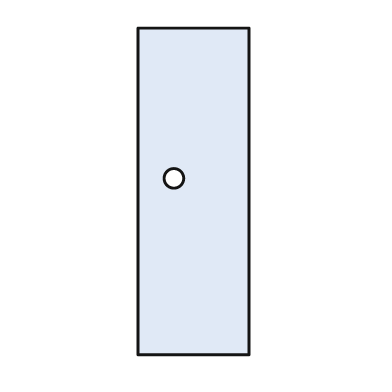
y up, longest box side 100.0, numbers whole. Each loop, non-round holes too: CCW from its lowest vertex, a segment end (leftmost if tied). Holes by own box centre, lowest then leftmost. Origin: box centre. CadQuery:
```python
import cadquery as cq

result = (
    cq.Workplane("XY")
    .moveTo(-17.0, -50.0)
    .lineTo(17.0, -50.0)
    .lineTo(17.0, 50.0)
    .lineTo(-17.0, 50.0)
    .close()
    .moveTo(-6.0, 4.0)
    .circle(3.0)
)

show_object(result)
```